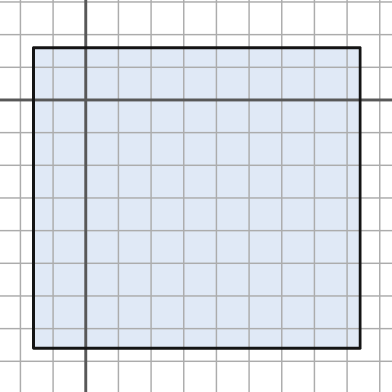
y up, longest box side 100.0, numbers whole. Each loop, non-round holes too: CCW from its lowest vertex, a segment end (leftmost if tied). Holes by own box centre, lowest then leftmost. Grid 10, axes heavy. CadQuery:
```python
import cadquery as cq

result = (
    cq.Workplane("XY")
    .moveTo(-16.0, -76.0)
    .lineTo(84.0, -76.0)
    .lineTo(84.0, 16.0)
    .lineTo(-16.0, 16.0)
    .close()
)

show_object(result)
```